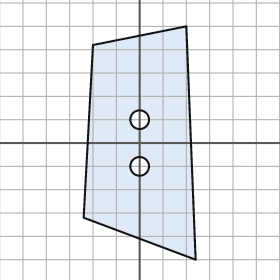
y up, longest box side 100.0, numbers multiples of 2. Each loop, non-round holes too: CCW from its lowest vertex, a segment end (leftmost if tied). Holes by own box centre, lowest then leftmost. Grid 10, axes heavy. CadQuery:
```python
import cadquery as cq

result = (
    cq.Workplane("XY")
    .moveTo(24.0, -50.0)
    .lineTo(20.0, 50.0)
    .lineTo(-20.0, 42.0)
    .lineTo(-24.0, -32.0)
    .close()
    .moveTo(0.0, -10.0)
    .circle(4.0)
    .moveTo(0.0, 10.0)
    .circle(4.0)
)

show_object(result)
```